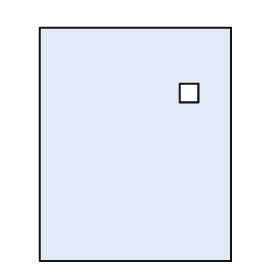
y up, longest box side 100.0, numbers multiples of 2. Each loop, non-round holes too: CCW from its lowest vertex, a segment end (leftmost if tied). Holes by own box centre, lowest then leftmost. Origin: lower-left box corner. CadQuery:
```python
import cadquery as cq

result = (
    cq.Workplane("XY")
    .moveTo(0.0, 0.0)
    .lineTo(82.0, 0.0)
    .lineTo(82.0, 100.0)
    .lineTo(0.0, 100.0)
    .close()
    .moveTo(60.0, 68.0)
    .lineTo(68.0, 68.0)
    .lineTo(68.0, 76.0)
    .lineTo(60.0, 76.0)
    .close()
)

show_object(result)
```